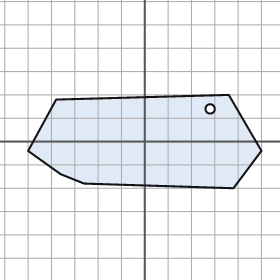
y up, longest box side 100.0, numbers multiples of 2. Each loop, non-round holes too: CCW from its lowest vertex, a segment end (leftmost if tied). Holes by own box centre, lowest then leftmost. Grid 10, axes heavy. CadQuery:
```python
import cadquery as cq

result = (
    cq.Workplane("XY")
    .moveTo(38.0, -20.0)
    .lineTo(50.0, -4.0)
    .lineTo(36.0, 20.0)
    .lineTo(-38.0, 18.0)
    .lineTo(-50.0, -4.0)
    .lineTo(-36.0, -14.0)
    .lineTo(-26.0, -18.0)
    .close()
    .moveTo(28.0, 14.0)
    .circle(2.0)
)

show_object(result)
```